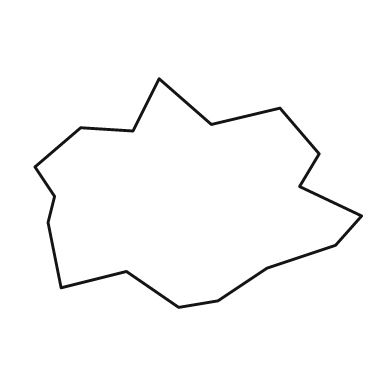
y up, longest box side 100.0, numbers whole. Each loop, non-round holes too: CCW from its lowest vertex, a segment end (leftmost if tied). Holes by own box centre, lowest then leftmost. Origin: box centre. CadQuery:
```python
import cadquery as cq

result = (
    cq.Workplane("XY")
    .moveTo(-6.0, -35.0)
    .lineTo(6.0, -33.0)
    .lineTo(21.0, -23.0)
    .lineTo(42.0, -16.0)
    .lineTo(50.0, -7.0)
    .lineTo(31.0, 2.0)
    .lineTo(37.0, 12.0)
    .lineTo(25.0, 26.0)
    .lineTo(4.0, 21.0)
    .lineTo(-12.0, 35.0)
    .lineTo(-20.0, 19.0)
    .lineTo(-36.0, 20.0)
    .lineTo(-50.0, 8.0)
    .lineTo(-44.0, -1.0)
    .lineTo(-46.0, -9.0)
    .lineTo(-42.0, -29.0)
    .lineTo(-22.0, -24.0)
    .close()
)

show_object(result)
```